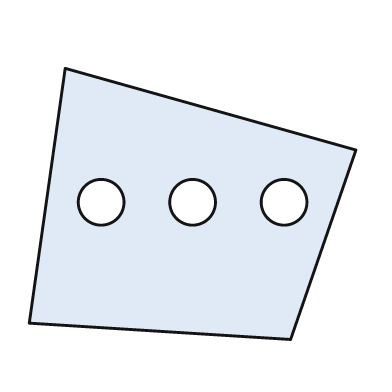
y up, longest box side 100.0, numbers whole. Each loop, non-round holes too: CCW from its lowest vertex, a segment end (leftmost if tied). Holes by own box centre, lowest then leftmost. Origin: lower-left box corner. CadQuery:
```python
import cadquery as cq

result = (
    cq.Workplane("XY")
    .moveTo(80.0, 0.0)
    .lineTo(100.0, 58.0)
    .lineTo(11.0, 83.0)
    .lineTo(0.0, 5.0)
    .close()
    .moveTo(22.0, 42.0)
    .circle(7.0)
    .moveTo(50.0, 42.0)
    .circle(7.0)
    .moveTo(78.0, 42.0)
    .circle(7.0)
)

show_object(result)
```